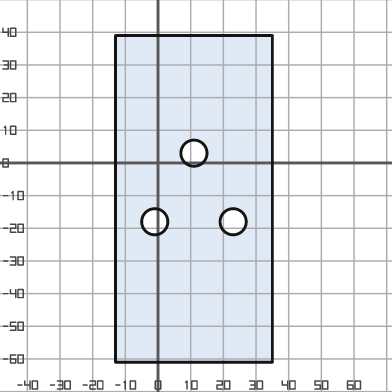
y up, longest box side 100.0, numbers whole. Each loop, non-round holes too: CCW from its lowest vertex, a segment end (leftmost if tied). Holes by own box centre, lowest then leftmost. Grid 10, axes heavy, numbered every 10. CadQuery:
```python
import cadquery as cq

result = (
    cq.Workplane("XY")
    .moveTo(-13.0, -61.0)
    .lineTo(35.0, -61.0)
    .lineTo(35.0, 39.0)
    .lineTo(-13.0, 39.0)
    .close()
    .moveTo(-1.0, -18.0)
    .circle(4.0)
    .moveTo(23.0, -18.0)
    .circle(4.0)
    .moveTo(11.0, 3.0)
    .circle(4.0)
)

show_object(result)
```